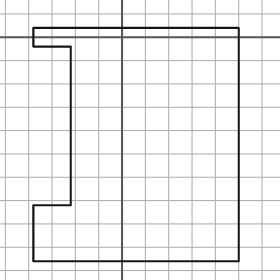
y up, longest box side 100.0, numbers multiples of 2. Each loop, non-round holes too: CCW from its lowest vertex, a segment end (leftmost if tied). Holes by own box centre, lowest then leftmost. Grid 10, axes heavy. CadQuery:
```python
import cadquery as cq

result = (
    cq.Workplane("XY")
    .moveTo(-38.0, -96.0)
    .lineTo(50.0, -96.0)
    .lineTo(50.0, 4.0)
    .lineTo(-38.0, 4.0)
    .lineTo(-38.0, -4.0)
    .lineTo(-22.0, -4.0)
    .lineTo(-22.0, -72.0)
    .lineTo(-38.0, -72.0)
    .close()
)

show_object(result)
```